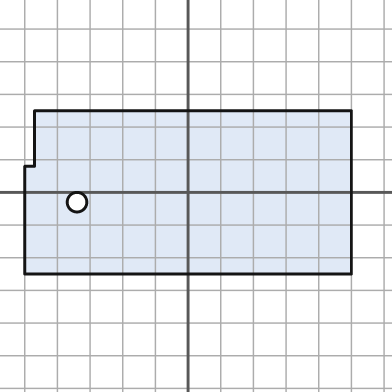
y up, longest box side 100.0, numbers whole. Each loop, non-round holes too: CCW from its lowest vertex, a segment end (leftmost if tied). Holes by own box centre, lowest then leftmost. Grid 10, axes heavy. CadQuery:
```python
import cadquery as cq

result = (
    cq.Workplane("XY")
    .moveTo(-50.0, -25.0)
    .lineTo(50.0, -25.0)
    .lineTo(50.0, 25.0)
    .lineTo(-47.0, 25.0)
    .lineTo(-47.0, 8.0)
    .lineTo(-50.0, 8.0)
    .close()
    .moveTo(-34.0, -3.0)
    .circle(3.0)
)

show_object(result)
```